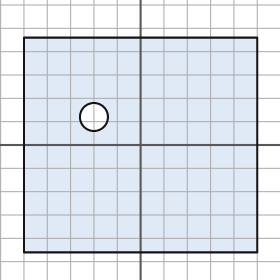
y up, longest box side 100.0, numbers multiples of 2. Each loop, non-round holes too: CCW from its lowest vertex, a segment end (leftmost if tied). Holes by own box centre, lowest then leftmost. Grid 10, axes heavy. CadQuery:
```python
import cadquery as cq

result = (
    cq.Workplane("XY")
    .moveTo(-50.0, -46.0)
    .lineTo(50.0, -46.0)
    .lineTo(50.0, 46.0)
    .lineTo(-50.0, 46.0)
    .close()
    .moveTo(-20.0, 12.0)
    .circle(6.0)
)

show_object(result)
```